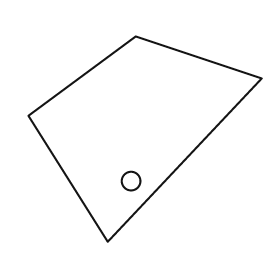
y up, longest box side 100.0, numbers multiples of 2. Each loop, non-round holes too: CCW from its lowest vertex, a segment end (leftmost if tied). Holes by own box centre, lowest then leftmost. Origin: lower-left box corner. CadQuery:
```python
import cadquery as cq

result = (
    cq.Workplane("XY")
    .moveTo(34.0, 0.0)
    .lineTo(100.0, 70.0)
    .lineTo(46.0, 88.0)
    .lineTo(0.0, 54.0)
    .close()
    .moveTo(44.0, 26.0)
    .circle(4.0)
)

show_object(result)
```